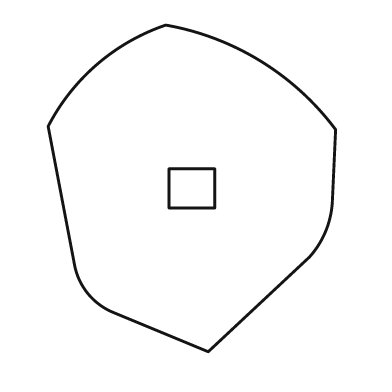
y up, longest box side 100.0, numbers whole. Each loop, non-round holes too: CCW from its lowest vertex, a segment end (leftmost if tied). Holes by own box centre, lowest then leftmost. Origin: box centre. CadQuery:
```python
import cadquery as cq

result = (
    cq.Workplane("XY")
    .moveTo(5.0, -50.0)
    .lineTo(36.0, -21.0)
    .threePointArc((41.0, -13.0), (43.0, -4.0))
    .lineTo(44.0, 18.0)
    .threePointArc((21.0, 39.0), (-8.0, 50.0))
    .threePointArc((-29.0, 38.0), (-44.0, 19.0))
    .lineTo(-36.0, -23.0)
    .threePointArc((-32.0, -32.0), (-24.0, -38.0))
    .close()
    .moveTo(-7.0, -6.0)
    .lineTo(7.0, -6.0)
    .lineTo(7.0, 6.0)
    .lineTo(-7.0, 6.0)
    .close()
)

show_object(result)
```